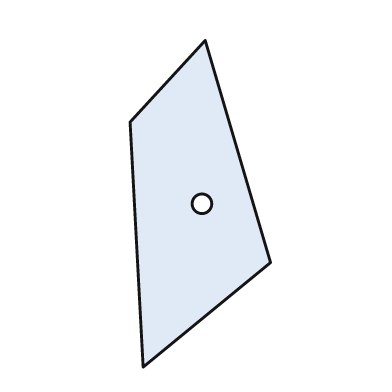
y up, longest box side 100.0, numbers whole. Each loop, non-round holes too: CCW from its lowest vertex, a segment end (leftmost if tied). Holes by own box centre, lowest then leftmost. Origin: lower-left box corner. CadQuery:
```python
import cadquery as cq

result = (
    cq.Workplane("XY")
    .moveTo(4.0, 0.0)
    .lineTo(43.0, 32.0)
    .lineTo(23.0, 100.0)
    .lineTo(0.0, 75.0)
    .close()
    .moveTo(22.0, 50.0)
    .circle(3.0)
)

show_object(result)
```